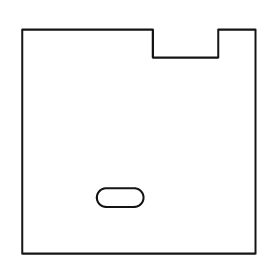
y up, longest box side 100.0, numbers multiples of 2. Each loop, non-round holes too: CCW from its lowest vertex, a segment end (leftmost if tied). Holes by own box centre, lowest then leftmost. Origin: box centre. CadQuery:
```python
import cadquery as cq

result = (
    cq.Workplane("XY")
    .moveTo(-50.0, -48.0)
    .lineTo(50.0, -48.0)
    .lineTo(50.0, 48.0)
    .lineTo(34.0, 48.0)
    .lineTo(34.0, 36.0)
    .lineTo(6.0, 36.0)
    .lineTo(6.0, 48.0)
    .lineTo(-50.0, 48.0)
    .close()
    .moveTo(-14.0, -28.0)
    .lineTo(-2.0, -28.0)
    .threePointArc((2.0, -24.0), (-2.0, -20.0))
    .lineTo(-14.0, -20.0)
    .threePointArc((-18.0, -24.0), (-14.0, -28.0))
    .close()
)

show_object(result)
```